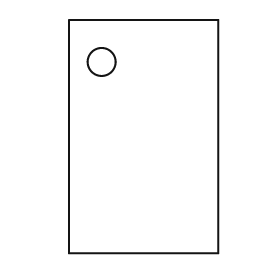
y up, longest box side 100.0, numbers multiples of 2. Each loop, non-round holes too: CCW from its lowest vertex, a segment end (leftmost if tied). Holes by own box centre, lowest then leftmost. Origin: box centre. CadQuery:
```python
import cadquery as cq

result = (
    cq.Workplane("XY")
    .moveTo(-32.0, -50.0)
    .lineTo(32.0, -50.0)
    .lineTo(32.0, 50.0)
    .lineTo(-32.0, 50.0)
    .close()
    .moveTo(-18.0, 32.0)
    .circle(6.0)
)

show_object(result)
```